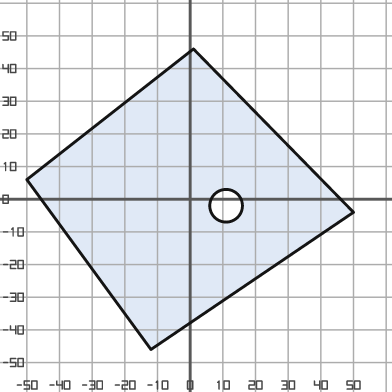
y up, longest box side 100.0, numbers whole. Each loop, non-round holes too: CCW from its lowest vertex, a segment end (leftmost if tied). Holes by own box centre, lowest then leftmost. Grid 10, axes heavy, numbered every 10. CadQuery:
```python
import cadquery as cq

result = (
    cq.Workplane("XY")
    .moveTo(-12.0, -46.0)
    .lineTo(50.0, -4.0)
    .lineTo(1.0, 46.0)
    .lineTo(-50.0, 6.0)
    .close()
    .moveTo(11.0, -2.0)
    .circle(5.0)
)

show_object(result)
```